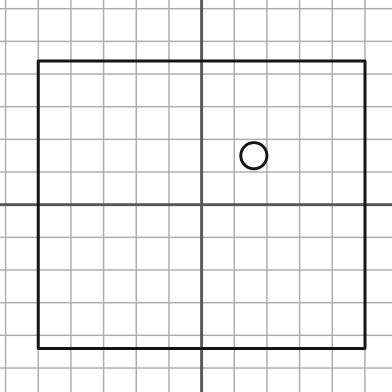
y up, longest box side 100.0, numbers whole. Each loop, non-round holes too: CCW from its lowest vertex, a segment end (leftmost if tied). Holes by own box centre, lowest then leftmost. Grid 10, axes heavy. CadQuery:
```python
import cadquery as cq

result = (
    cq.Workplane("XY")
    .moveTo(-50.0, -44.0)
    .lineTo(50.0, -44.0)
    .lineTo(50.0, 44.0)
    .lineTo(-50.0, 44.0)
    .close()
    .moveTo(16.0, 15.0)
    .circle(4.0)
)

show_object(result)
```